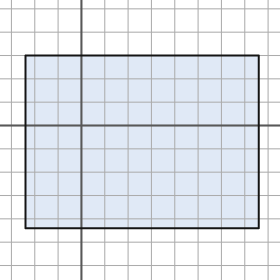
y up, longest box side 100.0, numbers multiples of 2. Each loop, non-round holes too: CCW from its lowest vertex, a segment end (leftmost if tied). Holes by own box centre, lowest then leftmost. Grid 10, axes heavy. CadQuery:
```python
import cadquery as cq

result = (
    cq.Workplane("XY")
    .moveTo(-24.0, -44.0)
    .lineTo(76.0, -44.0)
    .lineTo(76.0, 30.0)
    .lineTo(-24.0, 30.0)
    .close()
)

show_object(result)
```